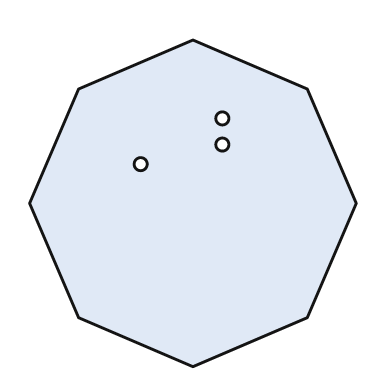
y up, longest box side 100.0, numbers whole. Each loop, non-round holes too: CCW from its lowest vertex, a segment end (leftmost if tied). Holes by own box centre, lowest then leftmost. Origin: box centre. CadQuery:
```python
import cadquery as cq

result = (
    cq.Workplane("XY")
    .moveTo(0.0, -50.0)
    .lineTo(35.0, -35.0)
    .lineTo(50.0, 0.0)
    .lineTo(35.0, 35.0)
    .lineTo(0.0, 50.0)
    .lineTo(-35.0, 35.0)
    .lineTo(-50.0, 0.0)
    .lineTo(-35.0, -35.0)
    .close()
    .moveTo(-16.0, 12.0)
    .circle(2.0)
    .moveTo(9.0, 18.0)
    .circle(2.0)
    .moveTo(9.0, 26.0)
    .circle(2.0)
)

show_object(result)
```